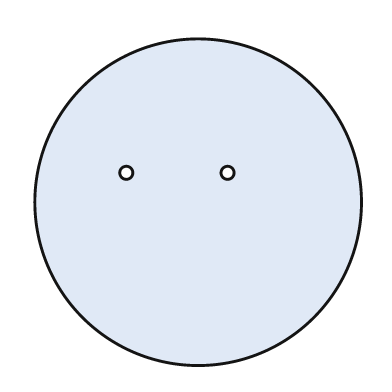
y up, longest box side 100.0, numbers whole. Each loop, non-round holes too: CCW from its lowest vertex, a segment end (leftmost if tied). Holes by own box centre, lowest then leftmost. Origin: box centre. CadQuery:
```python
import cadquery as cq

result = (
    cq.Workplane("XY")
    .moveTo(0.0, 0.0)
    .circle(50.0)
    .moveTo(-22.0, 9.0)
    .circle(2.0)
    .moveTo(9.0, 9.0)
    .circle(2.0)
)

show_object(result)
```